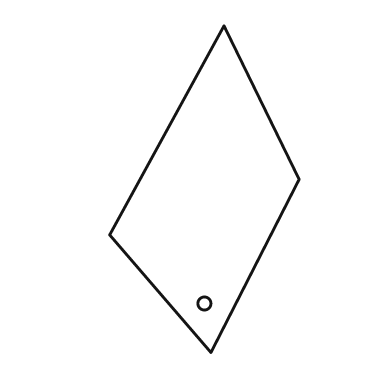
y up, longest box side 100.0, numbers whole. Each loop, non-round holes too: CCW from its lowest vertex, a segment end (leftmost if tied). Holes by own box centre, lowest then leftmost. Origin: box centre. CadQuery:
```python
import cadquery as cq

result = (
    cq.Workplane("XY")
    .moveTo(2.0, -50.0)
    .lineTo(29.0, 3.0)
    .lineTo(6.0, 50.0)
    .lineTo(-29.0, -14.0)
    .close()
    .moveTo(0.0, -35.0)
    .circle(2.0)
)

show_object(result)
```